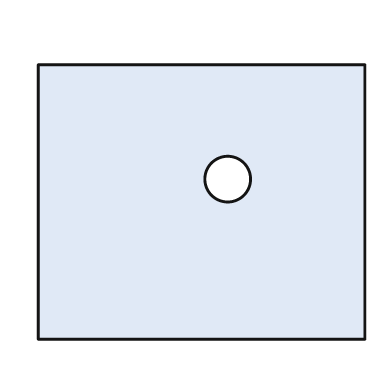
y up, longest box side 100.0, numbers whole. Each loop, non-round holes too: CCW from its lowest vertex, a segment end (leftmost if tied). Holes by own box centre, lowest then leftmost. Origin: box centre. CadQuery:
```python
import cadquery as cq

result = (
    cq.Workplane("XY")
    .moveTo(-50.0, -42.0)
    .lineTo(50.0, -42.0)
    .lineTo(50.0, 42.0)
    .lineTo(-50.0, 42.0)
    .close()
    .moveTo(8.0, 7.0)
    .circle(7.0)
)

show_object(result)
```